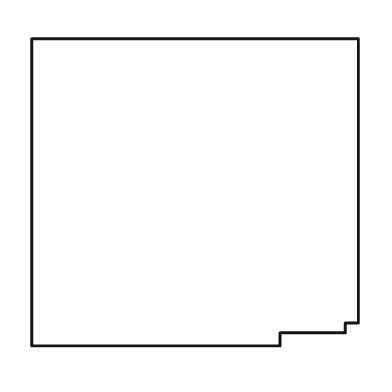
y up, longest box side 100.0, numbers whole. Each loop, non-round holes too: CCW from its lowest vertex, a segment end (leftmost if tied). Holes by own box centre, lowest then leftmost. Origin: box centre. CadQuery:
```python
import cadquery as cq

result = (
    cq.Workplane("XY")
    .moveTo(-50.0, -47.0)
    .lineTo(26.0, -47.0)
    .lineTo(26.0, -43.0)
    .lineTo(46.0, -43.0)
    .lineTo(46.0, -40.0)
    .lineTo(50.0, -40.0)
    .lineTo(50.0, 47.0)
    .lineTo(-50.0, 47.0)
    .close()
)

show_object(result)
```